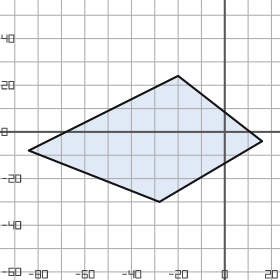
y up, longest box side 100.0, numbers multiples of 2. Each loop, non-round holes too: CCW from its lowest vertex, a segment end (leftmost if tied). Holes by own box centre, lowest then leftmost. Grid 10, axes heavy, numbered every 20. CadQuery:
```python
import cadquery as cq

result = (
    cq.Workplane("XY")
    .moveTo(-28.0, -30.0)
    .lineTo(16.0, -4.0)
    .lineTo(-20.0, 24.0)
    .lineTo(-84.0, -8.0)
    .close()
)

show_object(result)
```